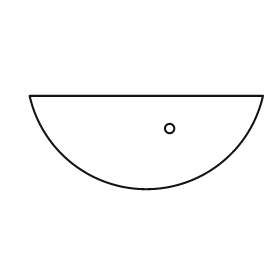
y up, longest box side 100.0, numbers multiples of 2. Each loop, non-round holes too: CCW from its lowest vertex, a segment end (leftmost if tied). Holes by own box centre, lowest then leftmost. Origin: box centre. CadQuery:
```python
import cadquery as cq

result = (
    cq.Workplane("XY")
    .moveTo(-50.0, 20.0)
    .threePointArc((0.0, -20.0), (50.0, 20.0))
    .close()
    .moveTo(10.0, 6.0)
    .circle(2.0)
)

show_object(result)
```